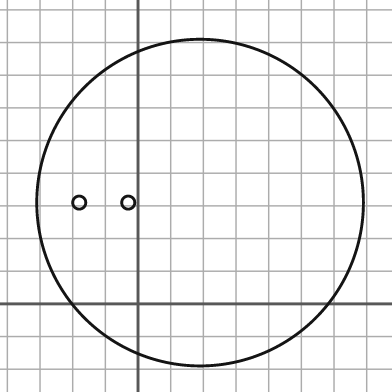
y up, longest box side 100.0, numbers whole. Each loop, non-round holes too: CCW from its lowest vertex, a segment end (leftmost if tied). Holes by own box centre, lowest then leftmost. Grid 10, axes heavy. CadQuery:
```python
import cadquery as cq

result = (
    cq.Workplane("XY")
    .moveTo(19.0, 31.0)
    .circle(50.0)
    .moveTo(-18.0, 31.0)
    .circle(2.0)
    .moveTo(-3.0, 31.0)
    .circle(2.0)
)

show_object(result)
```